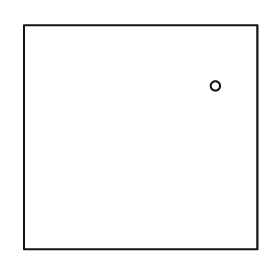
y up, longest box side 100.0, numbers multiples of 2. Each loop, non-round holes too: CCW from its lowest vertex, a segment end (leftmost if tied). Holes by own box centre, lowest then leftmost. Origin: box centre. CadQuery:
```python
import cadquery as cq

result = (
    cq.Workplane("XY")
    .moveTo(-50.0, -48.0)
    .lineTo(50.0, -48.0)
    .lineTo(50.0, 48.0)
    .lineTo(-50.0, 48.0)
    .close()
    .moveTo(32.0, 22.0)
    .circle(2.0)
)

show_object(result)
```